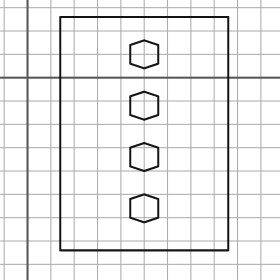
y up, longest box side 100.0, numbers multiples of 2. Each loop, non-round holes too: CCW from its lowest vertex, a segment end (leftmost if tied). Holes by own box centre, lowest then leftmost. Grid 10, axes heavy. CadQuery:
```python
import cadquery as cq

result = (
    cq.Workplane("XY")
    .moveTo(14.0, -74.0)
    .lineTo(86.0, -74.0)
    .lineTo(86.0, 26.0)
    .lineTo(14.0, 26.0)
    .close()
    .moveTo(50.0, -62.0)
    .lineTo(56.0, -60.0)
    .lineTo(56.0, -52.0)
    .lineTo(50.0, -50.0)
    .lineTo(44.0, -52.0)
    .lineTo(44.0, -60.0)
    .close()
    .moveTo(50.0, -40.0)
    .lineTo(56.0, -38.0)
    .lineTo(56.0, -30.0)
    .lineTo(50.0, -28.0)
    .lineTo(44.0, -30.0)
    .lineTo(44.0, -38.0)
    .close()
    .moveTo(50.0, -18.0)
    .lineTo(56.0, -16.0)
    .lineTo(56.0, -8.0)
    .lineTo(50.0, -6.0)
    .lineTo(44.0, -8.0)
    .lineTo(44.0, -16.0)
    .close()
    .moveTo(50.0, 4.0)
    .lineTo(56.0, 6.0)
    .lineTo(56.0, 14.0)
    .lineTo(50.0, 16.0)
    .lineTo(44.0, 14.0)
    .lineTo(44.0, 6.0)
    .close()
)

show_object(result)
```